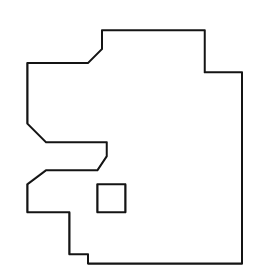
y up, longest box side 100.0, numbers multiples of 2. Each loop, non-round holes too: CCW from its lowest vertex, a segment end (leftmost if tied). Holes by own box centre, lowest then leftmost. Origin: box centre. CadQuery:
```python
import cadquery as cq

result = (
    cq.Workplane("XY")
    .moveTo(-20.0, -50.0)
    .lineTo(46.0, -50.0)
    .lineTo(46.0, 32.0)
    .lineTo(30.0, 32.0)
    .lineTo(30.0, 50.0)
    .lineTo(-14.0, 50.0)
    .lineTo(-14.0, 42.0)
    .lineTo(-20.0, 36.0)
    .lineTo(-46.0, 36.0)
    .lineTo(-46.0, 10.0)
    .lineTo(-38.0, 2.0)
    .lineTo(-12.0, 2.0)
    .lineTo(-12.0, -4.0)
    .lineTo(-16.0, -10.0)
    .lineTo(-38.0, -10.0)
    .lineTo(-46.0, -16.0)
    .lineTo(-46.0, -28.0)
    .lineTo(-28.0, -28.0)
    .lineTo(-28.0, -46.0)
    .lineTo(-20.0, -46.0)
    .close()
    .moveTo(-16.0, -28.0)
    .lineTo(-4.0, -28.0)
    .lineTo(-4.0, -16.0)
    .lineTo(-16.0, -16.0)
    .close()
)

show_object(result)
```